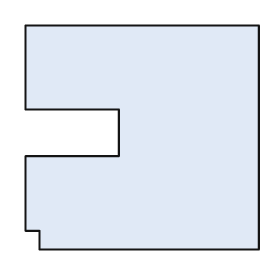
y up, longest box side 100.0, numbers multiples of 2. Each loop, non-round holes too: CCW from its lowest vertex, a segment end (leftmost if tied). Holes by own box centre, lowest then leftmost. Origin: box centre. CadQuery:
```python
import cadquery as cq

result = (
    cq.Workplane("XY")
    .moveTo(-44.0, -48.0)
    .lineTo(50.0, -48.0)
    .lineTo(50.0, 48.0)
    .lineTo(-50.0, 48.0)
    .lineTo(-50.0, 12.0)
    .lineTo(-10.0, 12.0)
    .lineTo(-10.0, -8.0)
    .lineTo(-50.0, -8.0)
    .lineTo(-50.0, -40.0)
    .lineTo(-44.0, -40.0)
    .close()
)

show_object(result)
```